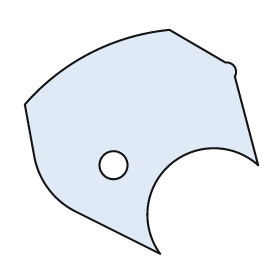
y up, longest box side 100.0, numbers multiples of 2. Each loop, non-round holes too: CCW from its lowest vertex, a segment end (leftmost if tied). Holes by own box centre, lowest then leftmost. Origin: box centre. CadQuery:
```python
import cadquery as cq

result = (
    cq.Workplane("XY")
    .moveTo(8.0, -48.0)
    .threePointArc((12.0, -10.0), (50.0, -10.0))
    .lineTo(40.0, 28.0)
    .threePointArc((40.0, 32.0), (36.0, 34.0))
    .lineTo(12.0, 48.0)
    .threePointArc((-22.0, 38.0), (-50.0, 16.0))
    .lineTo(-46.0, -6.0)
    .threePointArc((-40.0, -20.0), (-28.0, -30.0))
    .close()
    .moveTo(-12.0, -10.0)
    .circle(6.0)
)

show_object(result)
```